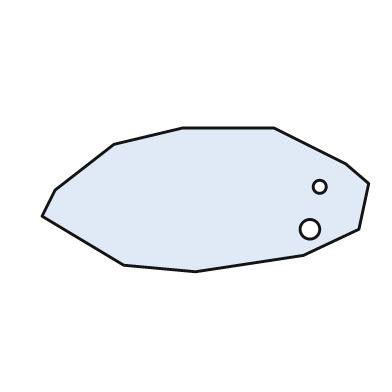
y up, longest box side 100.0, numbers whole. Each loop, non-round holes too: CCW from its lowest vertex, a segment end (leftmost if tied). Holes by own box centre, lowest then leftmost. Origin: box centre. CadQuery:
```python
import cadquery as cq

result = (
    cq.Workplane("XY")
    .moveTo(-3.0, -22.0)
    .lineTo(30.0, -17.0)
    .lineTo(47.0, -9.0)
    .lineTo(50.0, 5.0)
    .lineTo(43.0, 11.0)
    .lineTo(21.0, 22.0)
    .lineTo(-7.0, 22.0)
    .lineTo(-28.0, 17.0)
    .lineTo(-46.0, 3.0)
    .lineTo(-50.0, -5.0)
    .lineTo(-25.0, -20.0)
    .close()
    .moveTo(32.0, -9.0)
    .circle(3.0)
    .moveTo(35.0, 4.0)
    .circle(2.0)
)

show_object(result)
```